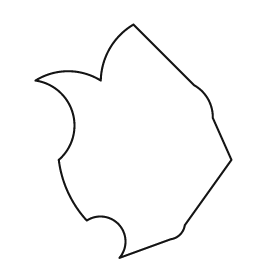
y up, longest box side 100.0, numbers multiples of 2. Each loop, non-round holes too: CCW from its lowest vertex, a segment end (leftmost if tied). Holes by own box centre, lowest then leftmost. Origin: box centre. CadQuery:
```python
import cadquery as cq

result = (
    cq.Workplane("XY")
    .moveTo(-6.0, -50.0)
    .lineTo(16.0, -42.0)
    .threePointArc((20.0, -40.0), (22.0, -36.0))
    .lineTo(42.0, -8.0)
    .lineTo(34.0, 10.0)
    .threePointArc((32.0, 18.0), (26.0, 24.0))
    .lineTo(0.0, 50.0)
    .threePointArc((-10.0, 40.0), (-14.0, 26.0))
    .threePointArc((-28.0, 30.0), (-42.0, 26.0))
    .threePointArc((-26.0, 12.0), (-32.0, -8.0))
    .threePointArc((-28.0, -22.0), (-20.0, -34.0))
    .threePointArc((-6.0, -36.0), (-6.0, -50.0))
    .close()
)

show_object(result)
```